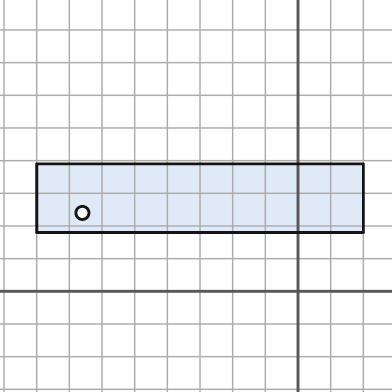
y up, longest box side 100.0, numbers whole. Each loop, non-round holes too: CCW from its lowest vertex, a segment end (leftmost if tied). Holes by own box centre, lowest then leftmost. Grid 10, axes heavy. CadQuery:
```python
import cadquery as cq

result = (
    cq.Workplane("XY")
    .moveTo(-80.0, 18.0)
    .lineTo(20.0, 18.0)
    .lineTo(20.0, 39.0)
    .lineTo(-80.0, 39.0)
    .close()
    .moveTo(-66.0, 24.0)
    .circle(2.0)
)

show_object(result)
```